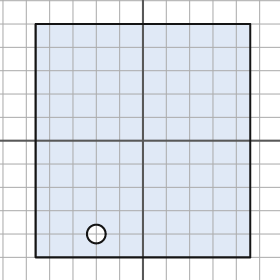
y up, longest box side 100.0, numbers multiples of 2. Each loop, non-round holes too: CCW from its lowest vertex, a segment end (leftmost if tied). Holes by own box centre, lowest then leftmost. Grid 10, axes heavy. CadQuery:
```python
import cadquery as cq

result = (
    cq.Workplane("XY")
    .moveTo(-46.0, -50.0)
    .lineTo(46.0, -50.0)
    .lineTo(46.0, 50.0)
    .lineTo(-46.0, 50.0)
    .close()
    .moveTo(-20.0, -40.0)
    .circle(4.0)
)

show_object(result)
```